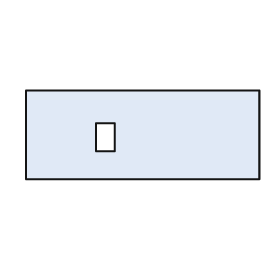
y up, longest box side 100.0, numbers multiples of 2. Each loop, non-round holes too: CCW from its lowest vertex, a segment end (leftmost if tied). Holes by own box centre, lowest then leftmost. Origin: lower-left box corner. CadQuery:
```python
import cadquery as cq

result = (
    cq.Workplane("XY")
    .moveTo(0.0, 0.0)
    .lineTo(100.0, 0.0)
    .lineTo(100.0, 38.0)
    .lineTo(0.0, 38.0)
    .close()
    .moveTo(30.0, 12.0)
    .lineTo(38.0, 12.0)
    .lineTo(38.0, 24.0)
    .lineTo(30.0, 24.0)
    .close()
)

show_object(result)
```